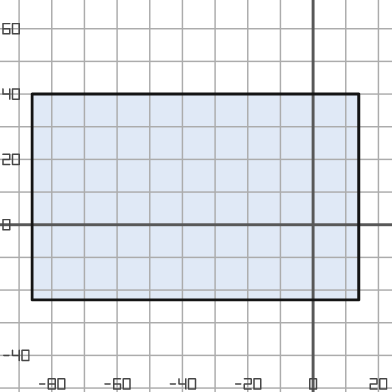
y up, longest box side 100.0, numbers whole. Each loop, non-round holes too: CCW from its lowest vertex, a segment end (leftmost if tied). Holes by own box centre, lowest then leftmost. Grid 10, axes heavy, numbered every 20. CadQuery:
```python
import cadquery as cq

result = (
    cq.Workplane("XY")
    .moveTo(-86.0, -23.0)
    .lineTo(14.0, -23.0)
    .lineTo(14.0, 40.0)
    .lineTo(-86.0, 40.0)
    .close()
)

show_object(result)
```